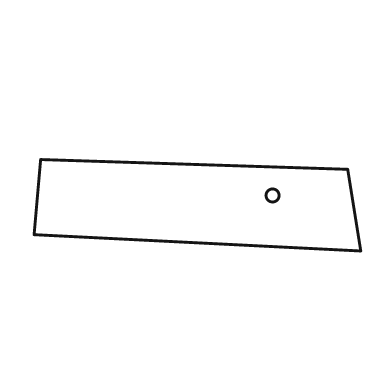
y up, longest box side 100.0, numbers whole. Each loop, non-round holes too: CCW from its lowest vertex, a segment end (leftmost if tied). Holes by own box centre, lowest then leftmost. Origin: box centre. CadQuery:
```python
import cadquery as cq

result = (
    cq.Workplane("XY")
    .moveTo(50.0, -14.0)
    .lineTo(46.0, 11.0)
    .lineTo(-48.0, 14.0)
    .lineTo(-50.0, -9.0)
    .close()
    .moveTo(23.0, 3.0)
    .circle(2.0)
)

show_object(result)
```